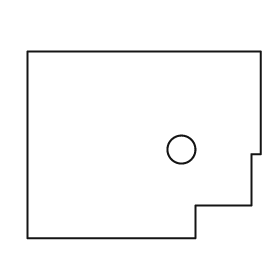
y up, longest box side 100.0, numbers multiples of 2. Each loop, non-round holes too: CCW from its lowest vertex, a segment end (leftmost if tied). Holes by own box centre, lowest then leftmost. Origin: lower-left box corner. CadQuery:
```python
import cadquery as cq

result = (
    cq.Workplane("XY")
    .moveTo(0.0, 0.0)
    .lineTo(72.0, 0.0)
    .lineTo(72.0, 14.0)
    .lineTo(96.0, 14.0)
    .lineTo(96.0, 36.0)
    .lineTo(100.0, 36.0)
    .lineTo(100.0, 80.0)
    .lineTo(0.0, 80.0)
    .close()
    .moveTo(66.0, 38.0)
    .circle(6.0)
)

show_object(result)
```